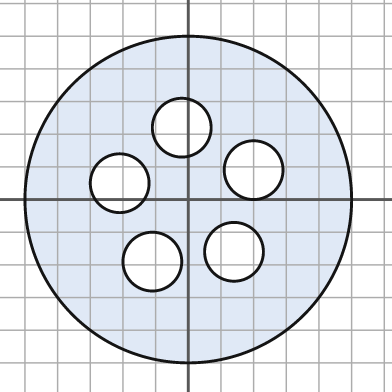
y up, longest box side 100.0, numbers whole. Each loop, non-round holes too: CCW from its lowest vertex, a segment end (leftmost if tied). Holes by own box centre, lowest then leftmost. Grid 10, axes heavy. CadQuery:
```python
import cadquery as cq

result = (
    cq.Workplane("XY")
    .moveTo(0.0, 0.0)
    .circle(50.0)
    .moveTo(-11.0, -19.0)
    .circle(9.0)
    .moveTo(14.0, -16.0)
    .circle(9.0)
    .moveTo(-21.0, 5.0)
    .circle(9.0)
    .moveTo(20.0, 9.0)
    .circle(9.0)
    .moveTo(-2.0, 22.0)
    .circle(9.0)
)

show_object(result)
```